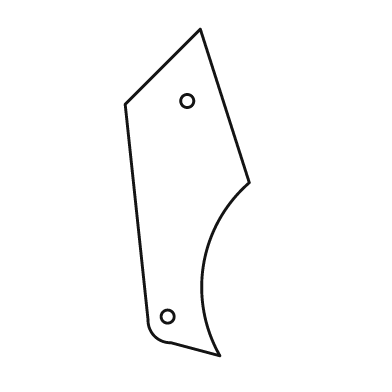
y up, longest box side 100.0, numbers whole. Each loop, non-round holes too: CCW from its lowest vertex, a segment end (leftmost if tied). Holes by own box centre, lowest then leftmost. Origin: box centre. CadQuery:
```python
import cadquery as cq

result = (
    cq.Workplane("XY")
    .moveTo(10.0, -50.0)
    .threePointArc((5.0, -22.0), (19.0, 3.0))
    .lineTo(4.0, 50.0)
    .lineTo(-19.0, 27.0)
    .lineTo(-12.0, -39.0)
    .threePointArc((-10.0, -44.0), (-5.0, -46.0))
    .close()
    .moveTo(-6.0, -38.0)
    .circle(2.0)
    .moveTo(0.0, 28.0)
    .circle(2.0)
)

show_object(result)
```